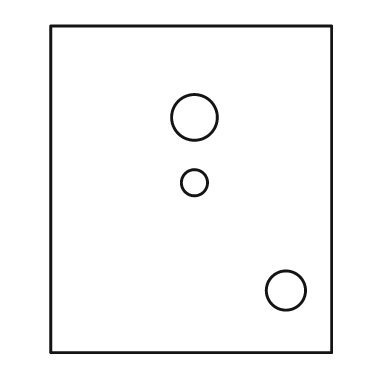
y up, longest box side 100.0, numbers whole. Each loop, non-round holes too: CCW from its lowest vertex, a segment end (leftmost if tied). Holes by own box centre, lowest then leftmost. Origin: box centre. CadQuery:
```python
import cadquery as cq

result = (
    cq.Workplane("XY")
    .moveTo(-43.0, -50.0)
    .lineTo(43.0, -50.0)
    .lineTo(43.0, 50.0)
    .lineTo(-43.0, 50.0)
    .close()
    .moveTo(29.0, -31.0)
    .circle(6.0)
    .moveTo(1.0, 2.0)
    .circle(4.0)
    .moveTo(1.0, 22.0)
    .circle(7.0)
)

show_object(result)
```